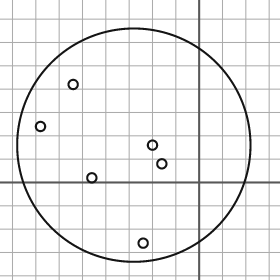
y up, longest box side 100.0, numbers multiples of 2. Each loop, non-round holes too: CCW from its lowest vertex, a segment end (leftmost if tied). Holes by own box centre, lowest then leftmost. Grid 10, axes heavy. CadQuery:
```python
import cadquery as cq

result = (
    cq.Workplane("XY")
    .moveTo(-28.0, 16.0)
    .circle(50.0)
    .moveTo(-24.0, -26.0)
    .circle(2.0)
    .moveTo(-46.0, 2.0)
    .circle(2.0)
    .moveTo(-16.0, 8.0)
    .circle(2.0)
    .moveTo(-20.0, 16.0)
    .circle(2.0)
    .moveTo(-68.0, 24.0)
    .circle(2.0)
    .moveTo(-54.0, 42.0)
    .circle(2.0)
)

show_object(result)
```